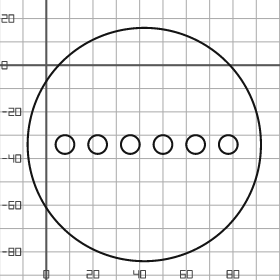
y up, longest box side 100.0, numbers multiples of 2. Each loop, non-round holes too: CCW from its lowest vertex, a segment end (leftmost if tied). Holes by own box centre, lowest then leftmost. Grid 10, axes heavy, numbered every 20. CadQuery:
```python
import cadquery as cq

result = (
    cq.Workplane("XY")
    .moveTo(42.0, -34.0)
    .circle(50.0)
    .moveTo(8.0, -34.0)
    .circle(4.0)
    .moveTo(22.0, -34.0)
    .circle(4.0)
    .moveTo(36.0, -34.0)
    .circle(4.0)
    .moveTo(50.0, -34.0)
    .circle(4.0)
    .moveTo(64.0, -34.0)
    .circle(4.0)
    .moveTo(78.0, -34.0)
    .circle(4.0)
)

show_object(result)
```